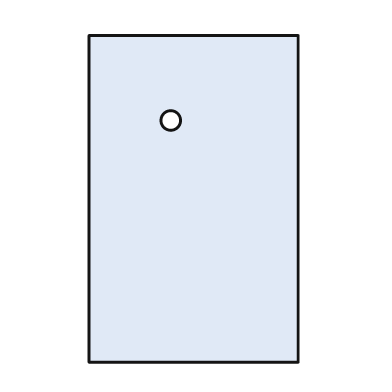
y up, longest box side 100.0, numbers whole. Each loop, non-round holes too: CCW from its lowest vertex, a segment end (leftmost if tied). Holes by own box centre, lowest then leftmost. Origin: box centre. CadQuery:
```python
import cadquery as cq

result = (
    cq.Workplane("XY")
    .moveTo(-32.0, -50.0)
    .lineTo(32.0, -50.0)
    .lineTo(32.0, 50.0)
    .lineTo(-32.0, 50.0)
    .close()
    .moveTo(-7.0, 24.0)
    .circle(3.0)
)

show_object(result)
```